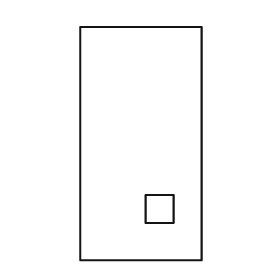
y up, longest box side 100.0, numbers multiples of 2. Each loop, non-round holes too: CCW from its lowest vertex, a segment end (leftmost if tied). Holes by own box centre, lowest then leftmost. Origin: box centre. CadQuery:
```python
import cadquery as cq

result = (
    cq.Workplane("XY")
    .moveTo(-26.0, -50.0)
    .lineTo(26.0, -50.0)
    .lineTo(26.0, 50.0)
    .lineTo(-26.0, 50.0)
    .close()
    .moveTo(2.0, -34.0)
    .lineTo(14.0, -34.0)
    .lineTo(14.0, -22.0)
    .lineTo(2.0, -22.0)
    .close()
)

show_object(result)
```